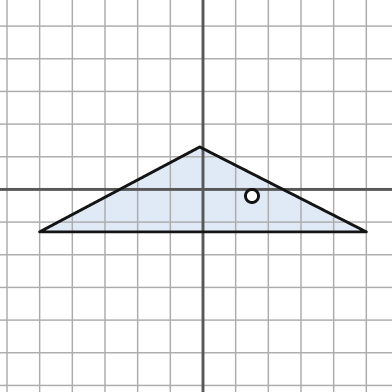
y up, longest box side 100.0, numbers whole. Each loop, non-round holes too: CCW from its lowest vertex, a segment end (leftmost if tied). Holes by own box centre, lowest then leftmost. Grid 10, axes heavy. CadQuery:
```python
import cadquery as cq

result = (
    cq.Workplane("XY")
    .moveTo(-50.0, -13.0)
    .lineTo(50.0, -13.0)
    .lineTo(-1.0, 13.0)
    .close()
    .moveTo(15.0, -2.0)
    .circle(2.0)
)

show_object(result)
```